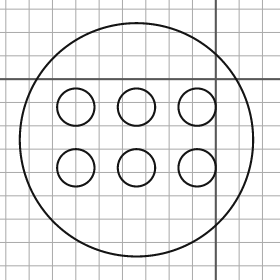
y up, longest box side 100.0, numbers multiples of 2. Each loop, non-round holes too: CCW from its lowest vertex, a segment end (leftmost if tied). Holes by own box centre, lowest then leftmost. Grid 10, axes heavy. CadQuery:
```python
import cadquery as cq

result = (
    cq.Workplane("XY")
    .moveTo(-34.0, -26.0)
    .circle(50.0)
    .moveTo(-60.0, -38.0)
    .circle(8.0)
    .moveTo(-34.0, -38.0)
    .circle(8.0)
    .moveTo(-8.0, -38.0)
    .circle(8.0)
    .moveTo(-60.0, -12.0)
    .circle(8.0)
    .moveTo(-34.0, -12.0)
    .circle(8.0)
    .moveTo(-8.0, -12.0)
    .circle(8.0)
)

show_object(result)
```